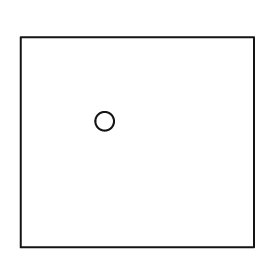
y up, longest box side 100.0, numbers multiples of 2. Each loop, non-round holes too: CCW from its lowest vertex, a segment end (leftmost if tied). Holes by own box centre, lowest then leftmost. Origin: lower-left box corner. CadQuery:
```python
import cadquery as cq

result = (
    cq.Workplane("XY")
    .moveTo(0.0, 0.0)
    .lineTo(100.0, 0.0)
    .lineTo(100.0, 90.0)
    .lineTo(0.0, 90.0)
    .close()
    .moveTo(36.0, 54.0)
    .circle(4.0)
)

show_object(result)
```